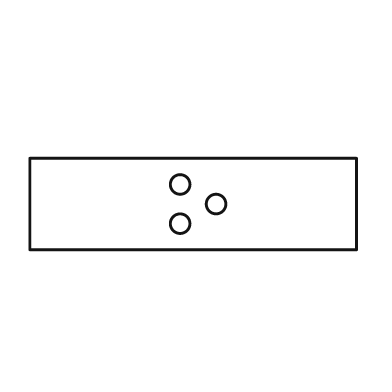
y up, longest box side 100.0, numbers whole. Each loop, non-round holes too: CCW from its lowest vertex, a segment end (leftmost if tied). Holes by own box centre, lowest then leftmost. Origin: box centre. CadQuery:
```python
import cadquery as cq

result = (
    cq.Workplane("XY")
    .moveTo(-50.0, -14.0)
    .lineTo(50.0, -14.0)
    .lineTo(50.0, 14.0)
    .lineTo(-50.0, 14.0)
    .close()
    .moveTo(-4.0, -6.0)
    .circle(3.0)
    .moveTo(7.0, 0.0)
    .circle(3.0)
    .moveTo(-4.0, 6.0)
    .circle(3.0)
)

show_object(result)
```